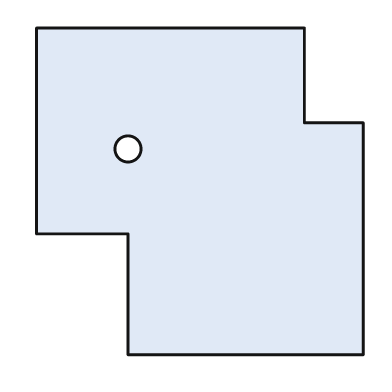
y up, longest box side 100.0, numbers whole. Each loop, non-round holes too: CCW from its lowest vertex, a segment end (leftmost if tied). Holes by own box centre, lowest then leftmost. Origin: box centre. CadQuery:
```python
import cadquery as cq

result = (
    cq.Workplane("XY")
    .moveTo(-22.0, -50.0)
    .lineTo(50.0, -50.0)
    .lineTo(50.0, 21.0)
    .lineTo(32.0, 21.0)
    .lineTo(32.0, 50.0)
    .lineTo(-50.0, 50.0)
    .lineTo(-50.0, -13.0)
    .lineTo(-22.0, -13.0)
    .close()
    .moveTo(-22.0, 13.0)
    .circle(4.0)
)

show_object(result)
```